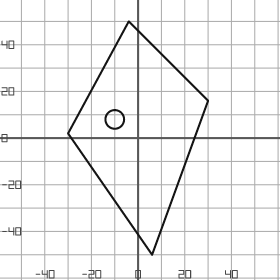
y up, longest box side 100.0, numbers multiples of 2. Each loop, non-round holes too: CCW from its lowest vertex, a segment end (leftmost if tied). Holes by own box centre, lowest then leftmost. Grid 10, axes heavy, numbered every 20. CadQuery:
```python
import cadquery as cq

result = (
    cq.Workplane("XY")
    .moveTo(6.0, -50.0)
    .lineTo(30.0, 16.0)
    .lineTo(-4.0, 50.0)
    .lineTo(-30.0, 2.0)
    .close()
    .moveTo(-10.0, 8.0)
    .circle(4.0)
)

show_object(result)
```